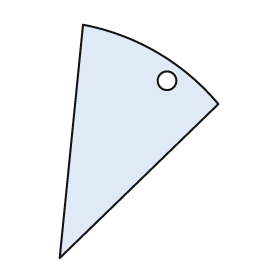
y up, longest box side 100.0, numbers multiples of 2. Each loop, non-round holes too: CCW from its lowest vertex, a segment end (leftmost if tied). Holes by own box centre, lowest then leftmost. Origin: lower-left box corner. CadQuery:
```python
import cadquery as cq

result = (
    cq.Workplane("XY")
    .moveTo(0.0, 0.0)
    .lineTo(68.0, 66.0)
    .threePointArc((42.0, 88.0), (10.0, 100.0))
    .close()
    .moveTo(46.0, 76.0)
    .circle(4.0)
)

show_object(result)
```